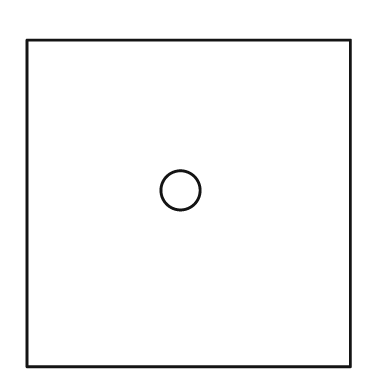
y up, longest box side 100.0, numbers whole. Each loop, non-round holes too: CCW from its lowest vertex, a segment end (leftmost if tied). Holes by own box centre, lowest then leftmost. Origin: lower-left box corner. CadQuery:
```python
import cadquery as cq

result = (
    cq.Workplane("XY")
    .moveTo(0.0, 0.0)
    .lineTo(99.0, 0.0)
    .lineTo(99.0, 100.0)
    .lineTo(0.0, 100.0)
    .close()
    .moveTo(47.0, 54.0)
    .circle(6.0)
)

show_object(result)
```